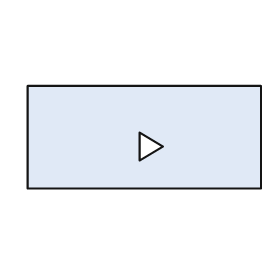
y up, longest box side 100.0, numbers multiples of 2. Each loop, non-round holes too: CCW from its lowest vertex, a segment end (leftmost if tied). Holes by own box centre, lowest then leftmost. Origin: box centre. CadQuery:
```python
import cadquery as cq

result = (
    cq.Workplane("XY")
    .moveTo(-50.0, -22.0)
    .lineTo(50.0, -22.0)
    .lineTo(50.0, 22.0)
    .lineTo(-50.0, 22.0)
    .close()
    .moveTo(-2.0, -10.0)
    .lineTo(8.0, -4.0)
    .lineTo(-2.0, 2.0)
    .close()
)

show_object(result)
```